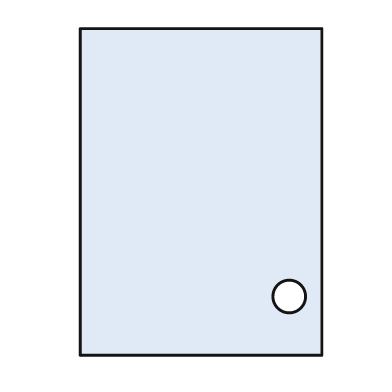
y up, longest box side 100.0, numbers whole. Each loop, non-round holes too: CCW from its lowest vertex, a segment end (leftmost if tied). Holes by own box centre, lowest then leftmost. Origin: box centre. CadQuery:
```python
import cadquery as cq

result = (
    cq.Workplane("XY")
    .moveTo(-37.0, -50.0)
    .lineTo(37.0, -50.0)
    .lineTo(37.0, 50.0)
    .lineTo(-37.0, 50.0)
    .close()
    .moveTo(27.0, -32.0)
    .circle(5.0)
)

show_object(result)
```